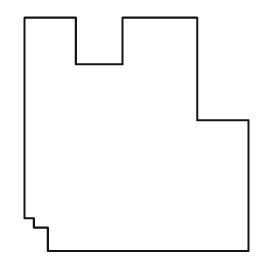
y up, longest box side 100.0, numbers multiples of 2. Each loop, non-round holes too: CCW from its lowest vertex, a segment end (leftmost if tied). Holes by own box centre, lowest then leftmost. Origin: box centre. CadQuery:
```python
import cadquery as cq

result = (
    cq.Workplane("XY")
    .moveTo(-38.0, -50.0)
    .lineTo(48.0, -50.0)
    .lineTo(48.0, 6.0)
    .lineTo(26.0, 6.0)
    .lineTo(26.0, 50.0)
    .lineTo(-6.0, 50.0)
    .lineTo(-6.0, 30.0)
    .lineTo(-26.0, 30.0)
    .lineTo(-26.0, 50.0)
    .lineTo(-48.0, 50.0)
    .lineTo(-48.0, -36.0)
    .lineTo(-44.0, -36.0)
    .lineTo(-44.0, -40.0)
    .lineTo(-38.0, -40.0)
    .close()
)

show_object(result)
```